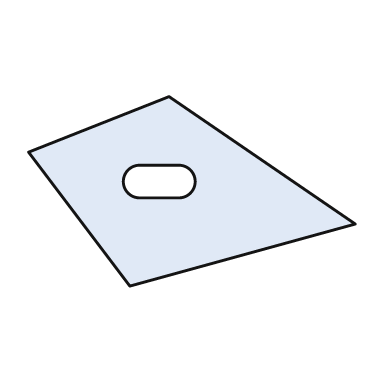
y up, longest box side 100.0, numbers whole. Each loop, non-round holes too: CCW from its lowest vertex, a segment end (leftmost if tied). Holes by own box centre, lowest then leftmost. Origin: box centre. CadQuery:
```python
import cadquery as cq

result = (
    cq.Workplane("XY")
    .moveTo(-19.0, -29.0)
    .lineTo(50.0, -10.0)
    .lineTo(-7.0, 29.0)
    .lineTo(-50.0, 12.0)
    .close()
    .moveTo(-16.0, -2.0)
    .lineTo(-4.0, -2.0)
    .threePointArc((1.0, 3.0), (-4.0, 8.0))
    .lineTo(-16.0, 8.0)
    .threePointArc((-21.0, 3.0), (-16.0, -2.0))
    .close()
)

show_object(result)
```